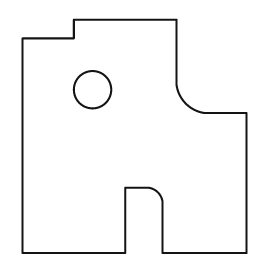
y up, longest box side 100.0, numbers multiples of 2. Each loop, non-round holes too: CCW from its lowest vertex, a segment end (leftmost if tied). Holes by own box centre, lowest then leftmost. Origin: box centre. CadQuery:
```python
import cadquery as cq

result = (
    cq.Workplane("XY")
    .moveTo(-48.0, -50.0)
    .lineTo(-4.0, -50.0)
    .lineTo(-4.0, -22.0)
    .lineTo(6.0, -22.0)
    .threePointArc((10.0, -24.0), (12.0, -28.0))
    .lineTo(12.0, -50.0)
    .lineTo(48.0, -50.0)
    .lineTo(48.0, 10.0)
    .lineTo(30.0, 10.0)
    .threePointArc((22.0, 14.0), (18.0, 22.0))
    .lineTo(18.0, 50.0)
    .lineTo(-26.0, 50.0)
    .lineTo(-26.0, 42.0)
    .lineTo(-48.0, 42.0)
    .close()
    .moveTo(-18.0, 20.0)
    .circle(8.0)
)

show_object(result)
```